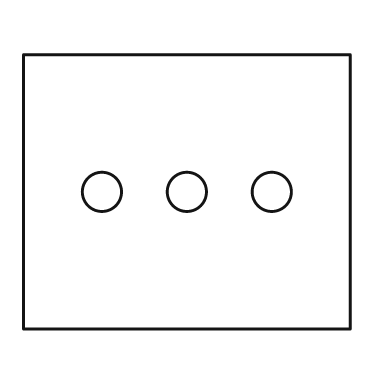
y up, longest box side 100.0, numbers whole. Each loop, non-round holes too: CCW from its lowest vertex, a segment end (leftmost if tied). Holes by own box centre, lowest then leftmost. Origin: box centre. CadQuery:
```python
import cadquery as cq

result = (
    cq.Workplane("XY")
    .moveTo(-50.0, -42.0)
    .lineTo(50.0, -42.0)
    .lineTo(50.0, 42.0)
    .lineTo(-50.0, 42.0)
    .close()
    .moveTo(-26.0, 0.0)
    .circle(6.0)
    .moveTo(0.0, 0.0)
    .circle(6.0)
    .moveTo(26.0, 0.0)
    .circle(6.0)
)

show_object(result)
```